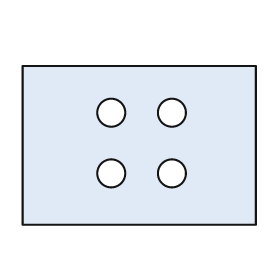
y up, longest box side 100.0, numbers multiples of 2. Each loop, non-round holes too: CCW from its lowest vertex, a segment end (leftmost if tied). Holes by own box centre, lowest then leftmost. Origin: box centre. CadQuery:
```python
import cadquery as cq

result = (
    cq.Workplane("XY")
    .moveTo(-50.0, -34.0)
    .lineTo(50.0, -34.0)
    .lineTo(50.0, 34.0)
    .lineTo(-50.0, 34.0)
    .close()
    .moveTo(-12.0, -12.0)
    .circle(6.0)
    .moveTo(14.0, -12.0)
    .circle(6.0)
    .moveTo(-12.0, 14.0)
    .circle(6.0)
    .moveTo(14.0, 14.0)
    .circle(6.0)
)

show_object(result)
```